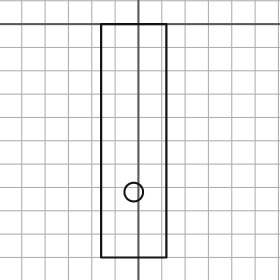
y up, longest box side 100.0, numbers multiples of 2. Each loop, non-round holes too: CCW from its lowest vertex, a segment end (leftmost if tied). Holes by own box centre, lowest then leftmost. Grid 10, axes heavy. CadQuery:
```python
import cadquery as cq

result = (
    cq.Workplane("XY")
    .moveTo(-16.0, -100.0)
    .lineTo(12.0, -100.0)
    .lineTo(12.0, 0.0)
    .lineTo(-16.0, 0.0)
    .close()
    .moveTo(-2.0, -72.0)
    .circle(4.0)
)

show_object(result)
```